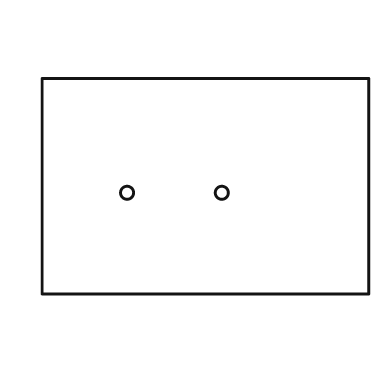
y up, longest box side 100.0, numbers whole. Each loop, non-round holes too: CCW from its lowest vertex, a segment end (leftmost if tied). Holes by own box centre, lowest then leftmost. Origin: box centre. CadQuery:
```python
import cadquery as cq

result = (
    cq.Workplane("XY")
    .moveTo(-50.0, -33.0)
    .lineTo(50.0, -33.0)
    .lineTo(50.0, 33.0)
    .lineTo(-50.0, 33.0)
    .close()
    .moveTo(-24.0, -2.0)
    .circle(2.0)
    .moveTo(5.0, -2.0)
    .circle(2.0)
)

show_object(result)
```